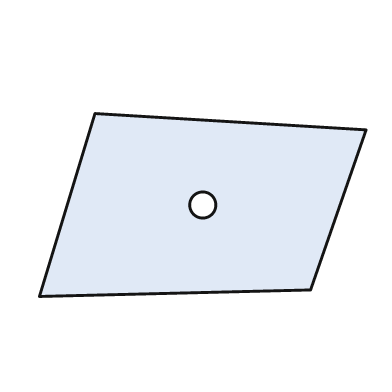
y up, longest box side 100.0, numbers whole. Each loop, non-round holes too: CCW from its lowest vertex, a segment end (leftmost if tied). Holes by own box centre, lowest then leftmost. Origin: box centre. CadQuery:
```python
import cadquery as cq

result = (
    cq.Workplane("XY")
    .moveTo(-50.0, -28.0)
    .lineTo(33.0, -26.0)
    .lineTo(50.0, 23.0)
    .lineTo(-33.0, 28.0)
    .close()
    .moveTo(0.0, 0.0)
    .circle(4.0)
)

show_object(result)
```